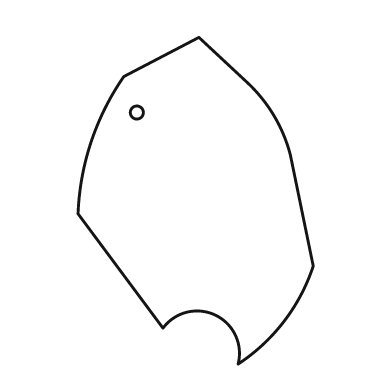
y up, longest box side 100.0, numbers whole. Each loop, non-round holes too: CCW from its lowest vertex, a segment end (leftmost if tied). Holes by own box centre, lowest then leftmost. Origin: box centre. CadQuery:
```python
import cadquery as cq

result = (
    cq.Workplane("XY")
    .moveTo(13.0, -50.0)
    .threePointArc((27.0, -37.0), (36.0, -20.0))
    .lineTo(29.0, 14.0)
    .threePointArc((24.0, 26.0), (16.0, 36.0))
    .lineTo(1.0, 50.0)
    .lineTo(-22.0, 38.0)
    .threePointArc((-32.0, 18.0), (-36.0, -4.0))
    .lineTo(-10.0, -39.0)
    .threePointArc((6.0, -35.0), (13.0, -50.0))
    .close()
    .moveTo(-18.0, 27.0)
    .circle(2.0)
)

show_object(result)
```